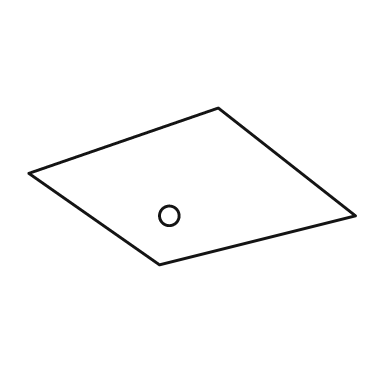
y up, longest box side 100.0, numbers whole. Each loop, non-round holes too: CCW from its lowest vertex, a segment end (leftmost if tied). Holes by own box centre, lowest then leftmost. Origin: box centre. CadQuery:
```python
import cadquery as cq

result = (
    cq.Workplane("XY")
    .moveTo(-10.0, -24.0)
    .lineTo(50.0, -9.0)
    .lineTo(8.0, 24.0)
    .lineTo(-50.0, 4.0)
    .close()
    .moveTo(-7.0, -9.0)
    .circle(3.0)
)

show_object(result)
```